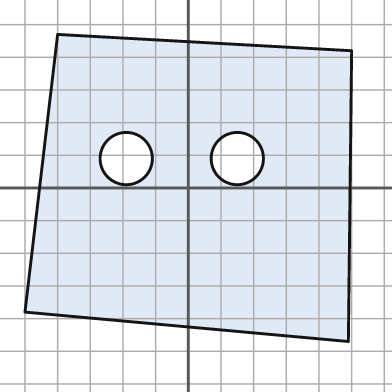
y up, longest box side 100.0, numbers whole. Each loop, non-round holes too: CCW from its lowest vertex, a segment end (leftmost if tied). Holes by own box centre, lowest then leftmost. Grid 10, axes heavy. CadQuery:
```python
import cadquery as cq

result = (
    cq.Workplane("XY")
    .moveTo(49.0, -47.0)
    .lineTo(50.0, 42.0)
    .lineTo(-40.0, 47.0)
    .lineTo(-50.0, -38.0)
    .close()
    .moveTo(-19.0, 9.0)
    .circle(8.0)
    .moveTo(15.0, 9.0)
    .circle(8.0)
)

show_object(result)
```